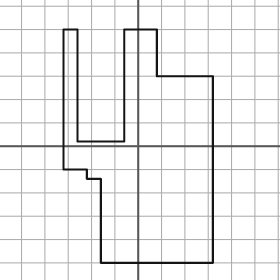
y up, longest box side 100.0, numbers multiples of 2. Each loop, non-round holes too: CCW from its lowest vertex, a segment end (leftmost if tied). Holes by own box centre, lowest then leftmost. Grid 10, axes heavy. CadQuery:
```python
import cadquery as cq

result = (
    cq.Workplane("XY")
    .moveTo(-16.0, -50.0)
    .lineTo(32.0, -50.0)
    .lineTo(32.0, 30.0)
    .lineTo(8.0, 30.0)
    .lineTo(8.0, 50.0)
    .lineTo(-6.0, 50.0)
    .lineTo(-6.0, 2.0)
    .lineTo(-26.0, 2.0)
    .lineTo(-26.0, 50.0)
    .lineTo(-32.0, 50.0)
    .lineTo(-32.0, -10.0)
    .lineTo(-22.0, -10.0)
    .lineTo(-22.0, -14.0)
    .lineTo(-16.0, -14.0)
    .close()
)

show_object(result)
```